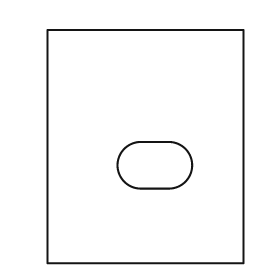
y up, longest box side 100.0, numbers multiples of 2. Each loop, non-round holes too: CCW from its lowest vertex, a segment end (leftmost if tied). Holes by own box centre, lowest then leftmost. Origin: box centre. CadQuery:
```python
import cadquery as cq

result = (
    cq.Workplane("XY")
    .moveTo(-42.0, -50.0)
    .lineTo(42.0, -50.0)
    .lineTo(42.0, 50.0)
    .lineTo(-42.0, 50.0)
    .close()
    .moveTo(-2.0, -18.0)
    .lineTo(10.0, -18.0)
    .threePointArc((20.0, -8.0), (10.0, 2.0))
    .lineTo(-2.0, 2.0)
    .threePointArc((-12.0, -8.0), (-2.0, -18.0))
    .close()
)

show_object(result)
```